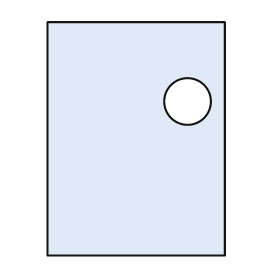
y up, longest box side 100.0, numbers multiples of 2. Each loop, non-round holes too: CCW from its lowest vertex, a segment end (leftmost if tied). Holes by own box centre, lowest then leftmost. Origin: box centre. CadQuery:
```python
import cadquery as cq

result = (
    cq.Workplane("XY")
    .moveTo(-38.0, -50.0)
    .lineTo(38.0, -50.0)
    .lineTo(38.0, 50.0)
    .lineTo(-38.0, 50.0)
    .close()
    .moveTo(22.0, 16.0)
    .circle(10.0)
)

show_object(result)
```